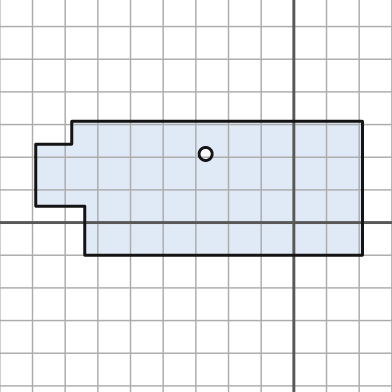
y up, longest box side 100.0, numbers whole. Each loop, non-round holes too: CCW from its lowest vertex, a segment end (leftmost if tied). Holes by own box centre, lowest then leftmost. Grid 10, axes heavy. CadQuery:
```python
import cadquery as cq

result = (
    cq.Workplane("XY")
    .moveTo(-64.0, -10.0)
    .lineTo(21.0, -10.0)
    .lineTo(21.0, 31.0)
    .lineTo(-68.0, 31.0)
    .lineTo(-68.0, 24.0)
    .lineTo(-79.0, 24.0)
    .lineTo(-79.0, 5.0)
    .lineTo(-64.0, 5.0)
    .close()
    .moveTo(-27.0, 21.0)
    .circle(2.0)
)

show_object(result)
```